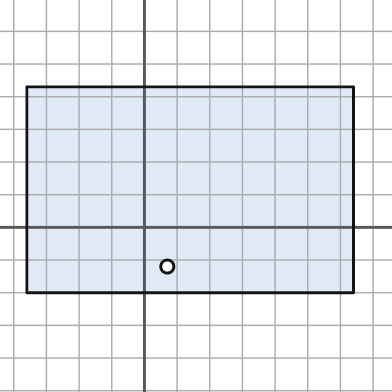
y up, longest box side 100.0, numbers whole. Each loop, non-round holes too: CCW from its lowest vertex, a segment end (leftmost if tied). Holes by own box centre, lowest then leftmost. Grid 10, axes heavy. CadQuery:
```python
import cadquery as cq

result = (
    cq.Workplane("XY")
    .moveTo(-36.0, -20.0)
    .lineTo(64.0, -20.0)
    .lineTo(64.0, 43.0)
    .lineTo(-36.0, 43.0)
    .close()
    .moveTo(7.0, -12.0)
    .circle(2.0)
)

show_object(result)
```